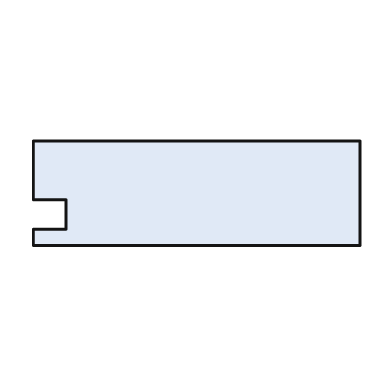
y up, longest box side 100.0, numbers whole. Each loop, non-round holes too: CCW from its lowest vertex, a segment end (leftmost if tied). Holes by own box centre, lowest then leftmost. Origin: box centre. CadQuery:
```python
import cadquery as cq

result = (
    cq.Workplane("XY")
    .moveTo(-50.0, -16.0)
    .lineTo(50.0, -16.0)
    .lineTo(50.0, 16.0)
    .lineTo(-50.0, 16.0)
    .lineTo(-50.0, -2.0)
    .lineTo(-40.0, -2.0)
    .lineTo(-40.0, -11.0)
    .lineTo(-50.0, -11.0)
    .close()
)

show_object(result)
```